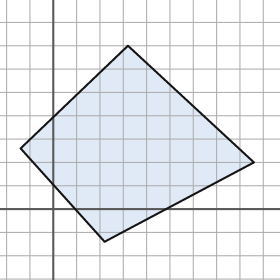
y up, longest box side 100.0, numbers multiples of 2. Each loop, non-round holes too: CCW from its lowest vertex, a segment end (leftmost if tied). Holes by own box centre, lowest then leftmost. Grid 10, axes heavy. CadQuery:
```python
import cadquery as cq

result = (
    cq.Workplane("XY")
    .moveTo(22.0, -14.0)
    .lineTo(86.0, 20.0)
    .lineTo(32.0, 70.0)
    .lineTo(-14.0, 26.0)
    .close()
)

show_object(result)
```